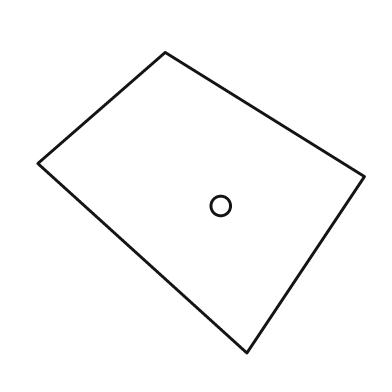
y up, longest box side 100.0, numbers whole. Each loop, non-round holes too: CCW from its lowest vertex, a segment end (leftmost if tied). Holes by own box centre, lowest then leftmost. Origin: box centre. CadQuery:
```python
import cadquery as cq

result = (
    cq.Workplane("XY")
    .moveTo(14.0, -46.0)
    .lineTo(50.0, 8.0)
    .lineTo(-11.0, 46.0)
    .lineTo(-50.0, 12.0)
    .close()
    .moveTo(6.0, -1.0)
    .circle(3.0)
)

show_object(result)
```